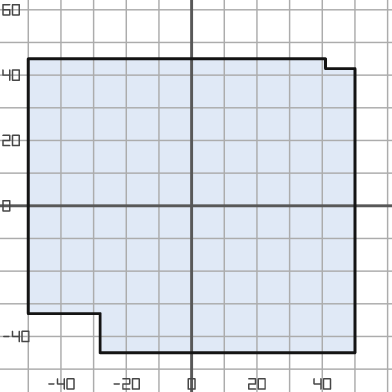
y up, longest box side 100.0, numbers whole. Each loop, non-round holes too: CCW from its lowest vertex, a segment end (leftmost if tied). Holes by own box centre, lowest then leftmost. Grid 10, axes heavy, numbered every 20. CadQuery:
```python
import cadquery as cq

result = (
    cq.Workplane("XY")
    .moveTo(-28.0, -45.0)
    .lineTo(50.0, -45.0)
    .lineTo(50.0, 42.0)
    .lineTo(41.0, 42.0)
    .lineTo(41.0, 45.0)
    .lineTo(-50.0, 45.0)
    .lineTo(-50.0, -33.0)
    .lineTo(-28.0, -33.0)
    .close()
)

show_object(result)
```